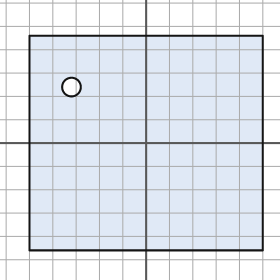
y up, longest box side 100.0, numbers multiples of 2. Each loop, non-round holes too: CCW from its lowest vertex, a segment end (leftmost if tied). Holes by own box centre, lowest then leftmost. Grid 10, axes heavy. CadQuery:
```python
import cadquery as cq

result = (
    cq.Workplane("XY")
    .moveTo(-50.0, -46.0)
    .lineTo(50.0, -46.0)
    .lineTo(50.0, 46.0)
    .lineTo(-50.0, 46.0)
    .close()
    .moveTo(-32.0, 24.0)
    .circle(4.0)
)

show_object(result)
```